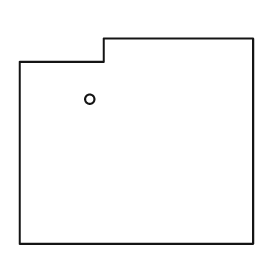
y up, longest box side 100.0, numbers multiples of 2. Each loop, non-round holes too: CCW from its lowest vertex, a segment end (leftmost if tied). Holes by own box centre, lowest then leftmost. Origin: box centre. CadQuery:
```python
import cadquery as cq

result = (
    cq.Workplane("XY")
    .moveTo(-50.0, -44.0)
    .lineTo(50.0, -44.0)
    .lineTo(50.0, 44.0)
    .lineTo(-14.0, 44.0)
    .lineTo(-14.0, 34.0)
    .lineTo(-50.0, 34.0)
    .close()
    .moveTo(-20.0, 18.0)
    .circle(2.0)
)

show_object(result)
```